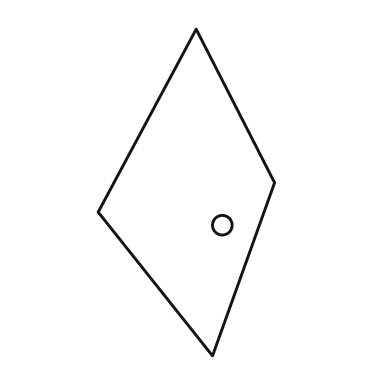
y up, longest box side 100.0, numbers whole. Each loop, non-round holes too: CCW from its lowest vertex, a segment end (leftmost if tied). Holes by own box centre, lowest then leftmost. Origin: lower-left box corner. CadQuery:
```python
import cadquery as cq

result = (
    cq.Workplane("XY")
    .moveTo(35.0, 0.0)
    .lineTo(54.0, 53.0)
    .lineTo(30.0, 100.0)
    .lineTo(0.0, 44.0)
    .close()
    .moveTo(38.0, 40.0)
    .circle(3.0)
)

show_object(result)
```